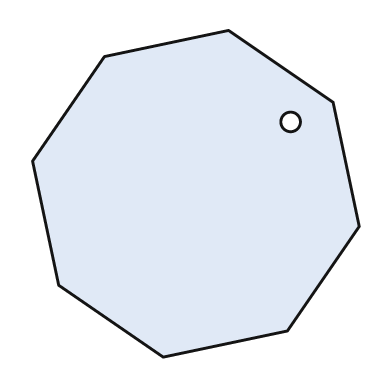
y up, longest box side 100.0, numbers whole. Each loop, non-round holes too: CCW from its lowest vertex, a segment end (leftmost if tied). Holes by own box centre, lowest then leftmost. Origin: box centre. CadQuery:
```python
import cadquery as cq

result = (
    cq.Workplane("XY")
    .moveTo(-10.0, -50.0)
    .lineTo(28.0, -42.0)
    .lineTo(50.0, -10.0)
    .lineTo(42.0, 28.0)
    .lineTo(10.0, 50.0)
    .lineTo(-28.0, 42.0)
    .lineTo(-50.0, 10.0)
    .lineTo(-42.0, -28.0)
    .close()
    .moveTo(29.0, 22.0)
    .circle(3.0)
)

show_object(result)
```